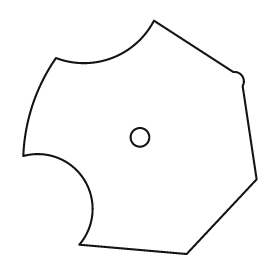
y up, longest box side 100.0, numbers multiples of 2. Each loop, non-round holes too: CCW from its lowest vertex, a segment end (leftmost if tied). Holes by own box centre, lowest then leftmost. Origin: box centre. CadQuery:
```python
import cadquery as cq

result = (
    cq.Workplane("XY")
    .moveTo(20.0, -50.0)
    .lineTo(50.0, -18.0)
    .lineTo(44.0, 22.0)
    .threePointArc((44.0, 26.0), (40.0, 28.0))
    .lineTo(6.0, 50.0)
    .threePointArc((-12.0, 34.0), (-36.0, 34.0))
    .threePointArc((-46.0, 14.0), (-50.0, -8.0))
    .threePointArc((-24.0, -18.0), (-26.0, -46.0))
    .close()
    .moveTo(0.0, 0.0)
    .circle(4.0)
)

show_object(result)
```